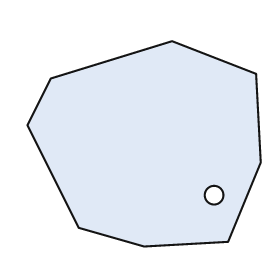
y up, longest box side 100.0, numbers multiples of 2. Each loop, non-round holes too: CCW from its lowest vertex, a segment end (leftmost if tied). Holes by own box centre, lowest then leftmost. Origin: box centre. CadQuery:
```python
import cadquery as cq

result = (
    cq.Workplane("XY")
    .moveTo(0.0, -44.0)
    .lineTo(36.0, -42.0)
    .lineTo(50.0, -8.0)
    .lineTo(48.0, 30.0)
    .lineTo(12.0, 44.0)
    .lineTo(-40.0, 28.0)
    .lineTo(-50.0, 8.0)
    .lineTo(-28.0, -36.0)
    .close()
    .moveTo(30.0, -22.0)
    .circle(4.0)
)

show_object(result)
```